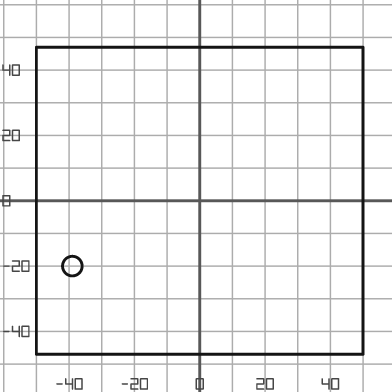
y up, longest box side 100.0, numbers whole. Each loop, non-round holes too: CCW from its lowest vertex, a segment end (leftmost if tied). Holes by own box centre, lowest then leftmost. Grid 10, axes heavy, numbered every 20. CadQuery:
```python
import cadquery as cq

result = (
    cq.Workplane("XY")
    .moveTo(-50.0, -47.0)
    .lineTo(50.0, -47.0)
    .lineTo(50.0, 47.0)
    .lineTo(-50.0, 47.0)
    .close()
    .moveTo(-39.0, -20.0)
    .circle(3.0)
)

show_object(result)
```